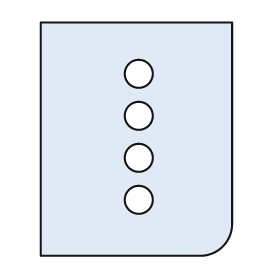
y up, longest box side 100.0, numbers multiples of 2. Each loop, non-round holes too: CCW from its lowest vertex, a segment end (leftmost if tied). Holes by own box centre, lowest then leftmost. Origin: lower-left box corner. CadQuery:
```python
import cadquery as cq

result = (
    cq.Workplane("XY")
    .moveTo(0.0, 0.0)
    .lineTo(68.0, 0.0)
    .threePointArc((78.0, 4.0), (82.0, 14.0))
    .lineTo(82.0, 100.0)
    .lineTo(0.0, 100.0)
    .close()
    .moveTo(42.0, 24.0)
    .circle(6.0)
    .moveTo(42.0, 42.0)
    .circle(6.0)
    .moveTo(42.0, 60.0)
    .circle(6.0)
    .moveTo(42.0, 78.0)
    .circle(6.0)
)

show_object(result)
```